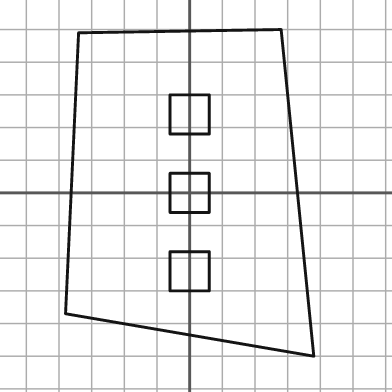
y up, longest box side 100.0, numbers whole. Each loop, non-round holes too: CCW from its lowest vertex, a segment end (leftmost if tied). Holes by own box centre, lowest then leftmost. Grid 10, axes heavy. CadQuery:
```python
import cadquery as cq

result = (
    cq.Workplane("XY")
    .moveTo(38.0, -50.0)
    .lineTo(28.0, 50.0)
    .lineTo(-34.0, 49.0)
    .lineTo(-38.0, -37.0)
    .close()
    .moveTo(-6.0, -30.0)
    .lineTo(6.0, -30.0)
    .lineTo(6.0, -18.0)
    .lineTo(-6.0, -18.0)
    .close()
    .moveTo(-6.0, -6.0)
    .lineTo(6.0, -6.0)
    .lineTo(6.0, 6.0)
    .lineTo(-6.0, 6.0)
    .close()
    .moveTo(-6.0, 18.0)
    .lineTo(6.0, 18.0)
    .lineTo(6.0, 30.0)
    .lineTo(-6.0, 30.0)
    .close()
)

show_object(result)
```